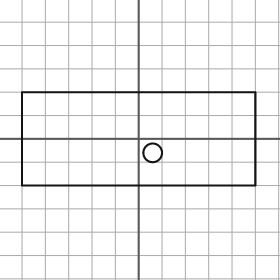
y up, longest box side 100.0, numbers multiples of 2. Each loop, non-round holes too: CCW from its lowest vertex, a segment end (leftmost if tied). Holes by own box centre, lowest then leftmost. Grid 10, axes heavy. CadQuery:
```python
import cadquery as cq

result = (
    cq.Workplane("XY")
    .moveTo(-50.0, -20.0)
    .lineTo(50.0, -20.0)
    .lineTo(50.0, 20.0)
    .lineTo(-50.0, 20.0)
    .close()
    .moveTo(6.0, -6.0)
    .circle(4.0)
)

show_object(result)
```